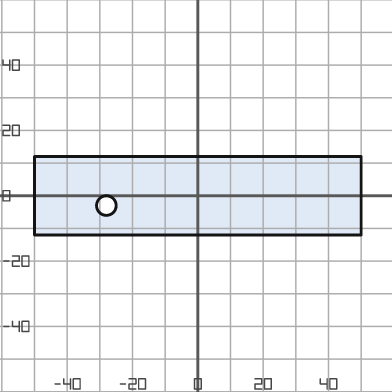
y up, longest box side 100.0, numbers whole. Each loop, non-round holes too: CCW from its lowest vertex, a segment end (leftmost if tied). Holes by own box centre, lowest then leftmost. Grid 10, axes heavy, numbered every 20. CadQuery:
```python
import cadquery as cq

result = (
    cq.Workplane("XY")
    .moveTo(-50.0, -12.0)
    .lineTo(50.0, -12.0)
    .lineTo(50.0, 12.0)
    .lineTo(-50.0, 12.0)
    .close()
    .moveTo(-28.0, -3.0)
    .circle(3.0)
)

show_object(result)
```